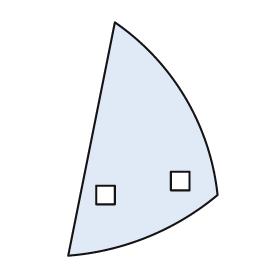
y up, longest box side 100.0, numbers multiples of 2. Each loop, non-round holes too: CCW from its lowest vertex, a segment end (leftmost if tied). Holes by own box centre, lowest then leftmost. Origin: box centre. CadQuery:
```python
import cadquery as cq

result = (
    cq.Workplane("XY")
    .moveTo(-32.0, -50.0)
    .threePointArc((2.0, -42.0), (32.0, -24.0))
    .threePointArc((18.0, 18.0), (-12.0, 50.0))
    .close()
    .moveTo(-20.0, -28.0)
    .lineTo(-12.0, -28.0)
    .lineTo(-12.0, -20.0)
    .lineTo(-20.0, -20.0)
    .close()
    .moveTo(12.0, -22.0)
    .lineTo(20.0, -22.0)
    .lineTo(20.0, -14.0)
    .lineTo(12.0, -14.0)
    .close()
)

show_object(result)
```